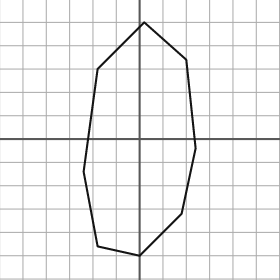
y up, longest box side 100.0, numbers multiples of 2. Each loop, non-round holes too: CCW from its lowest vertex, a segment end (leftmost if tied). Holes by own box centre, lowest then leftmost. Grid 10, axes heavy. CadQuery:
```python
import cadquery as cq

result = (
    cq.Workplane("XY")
    .moveTo(0.0, -50.0)
    .lineTo(18.0, -32.0)
    .lineTo(24.0, -4.0)
    .lineTo(20.0, 34.0)
    .lineTo(2.0, 50.0)
    .lineTo(-18.0, 30.0)
    .lineTo(-24.0, -14.0)
    .lineTo(-18.0, -46.0)
    .close()
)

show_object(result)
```